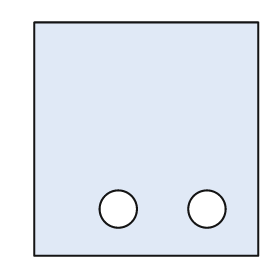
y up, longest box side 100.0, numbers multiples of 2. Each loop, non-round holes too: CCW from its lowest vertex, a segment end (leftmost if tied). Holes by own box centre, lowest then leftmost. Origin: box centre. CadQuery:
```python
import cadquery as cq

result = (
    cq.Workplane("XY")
    .moveTo(-48.0, -50.0)
    .lineTo(48.0, -50.0)
    .lineTo(48.0, 50.0)
    .lineTo(-48.0, 50.0)
    .close()
    .moveTo(-12.0, -30.0)
    .circle(8.0)
    .moveTo(26.0, -30.0)
    .circle(8.0)
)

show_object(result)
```